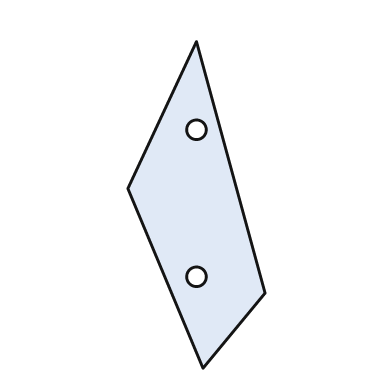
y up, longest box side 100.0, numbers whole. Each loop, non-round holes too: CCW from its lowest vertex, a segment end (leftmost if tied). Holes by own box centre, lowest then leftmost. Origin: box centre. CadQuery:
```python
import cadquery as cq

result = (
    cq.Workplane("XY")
    .moveTo(2.0, -50.0)
    .lineTo(21.0, -27.0)
    .lineTo(0.0, 50.0)
    .lineTo(-21.0, 5.0)
    .close()
    .moveTo(0.0, -22.0)
    .circle(3.0)
    .moveTo(0.0, 23.0)
    .circle(3.0)
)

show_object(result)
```